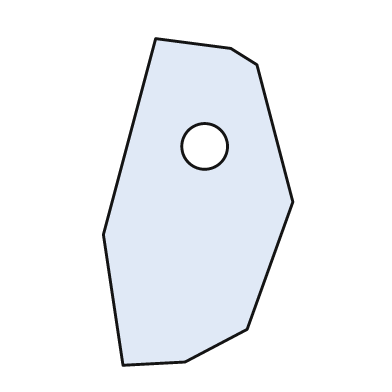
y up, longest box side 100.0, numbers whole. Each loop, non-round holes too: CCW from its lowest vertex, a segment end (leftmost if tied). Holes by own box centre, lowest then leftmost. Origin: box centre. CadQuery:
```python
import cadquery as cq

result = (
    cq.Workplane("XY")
    .moveTo(-23.0, -50.0)
    .lineTo(-4.0, -49.0)
    .lineTo(15.0, -39.0)
    .lineTo(29.0, 0.0)
    .lineTo(18.0, 42.0)
    .lineTo(10.0, 47.0)
    .lineTo(-13.0, 50.0)
    .lineTo(-29.0, -10.0)
    .close()
    .moveTo(2.0, 17.0)
    .circle(7.0)
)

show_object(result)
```